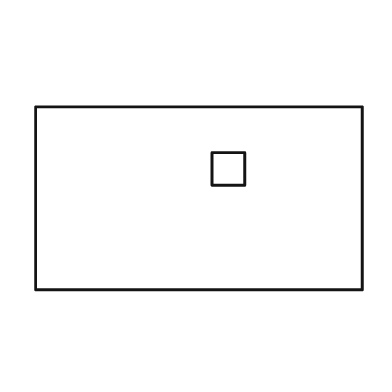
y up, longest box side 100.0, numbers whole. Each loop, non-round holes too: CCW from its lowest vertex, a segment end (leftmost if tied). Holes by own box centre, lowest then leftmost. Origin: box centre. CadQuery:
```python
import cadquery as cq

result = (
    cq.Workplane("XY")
    .moveTo(-50.0, -28.0)
    .lineTo(50.0, -28.0)
    .lineTo(50.0, 28.0)
    .lineTo(-50.0, 28.0)
    .close()
    .moveTo(4.0, 4.0)
    .lineTo(14.0, 4.0)
    .lineTo(14.0, 14.0)
    .lineTo(4.0, 14.0)
    .close()
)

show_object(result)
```